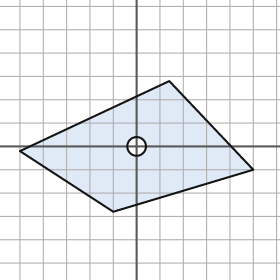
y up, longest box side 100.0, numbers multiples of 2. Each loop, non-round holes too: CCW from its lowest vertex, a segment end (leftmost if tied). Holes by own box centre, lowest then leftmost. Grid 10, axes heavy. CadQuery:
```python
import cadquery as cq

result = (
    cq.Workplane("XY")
    .moveTo(-10.0, -28.0)
    .lineTo(50.0, -10.0)
    .lineTo(14.0, 28.0)
    .lineTo(-50.0, -2.0)
    .close()
    .moveTo(0.0, 0.0)
    .circle(4.0)
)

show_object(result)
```